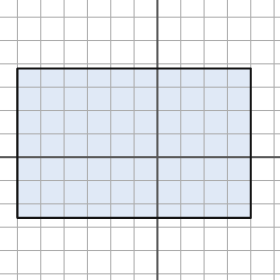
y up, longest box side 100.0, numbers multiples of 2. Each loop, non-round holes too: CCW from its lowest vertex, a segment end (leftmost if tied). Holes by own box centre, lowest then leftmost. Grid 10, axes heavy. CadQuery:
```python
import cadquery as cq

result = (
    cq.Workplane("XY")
    .moveTo(-60.0, -26.0)
    .lineTo(40.0, -26.0)
    .lineTo(40.0, 38.0)
    .lineTo(-60.0, 38.0)
    .close()
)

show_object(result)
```